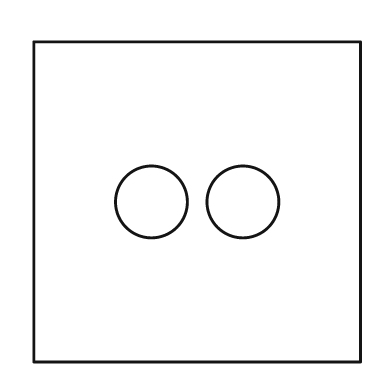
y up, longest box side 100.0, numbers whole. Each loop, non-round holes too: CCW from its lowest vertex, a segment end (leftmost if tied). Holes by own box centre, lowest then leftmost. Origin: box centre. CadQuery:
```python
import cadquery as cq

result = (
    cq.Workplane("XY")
    .moveTo(-50.0, -49.0)
    .lineTo(50.0, -49.0)
    .lineTo(50.0, 49.0)
    .lineTo(-50.0, 49.0)
    .close()
    .moveTo(-14.0, 0.0)
    .circle(11.0)
    .moveTo(14.0, 0.0)
    .circle(11.0)
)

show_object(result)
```